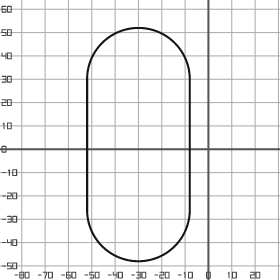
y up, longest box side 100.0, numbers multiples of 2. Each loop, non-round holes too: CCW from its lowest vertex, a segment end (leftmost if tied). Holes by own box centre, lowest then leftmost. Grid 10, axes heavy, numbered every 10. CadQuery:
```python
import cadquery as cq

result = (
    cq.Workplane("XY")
    .moveTo(-52.0, -26.0)
    .threePointArc((-30.0, -48.0), (-8.0, -26.0))
    .lineTo(-8.0, 30.0)
    .threePointArc((-30.0, 52.0), (-52.0, 30.0))
    .close()
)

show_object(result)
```